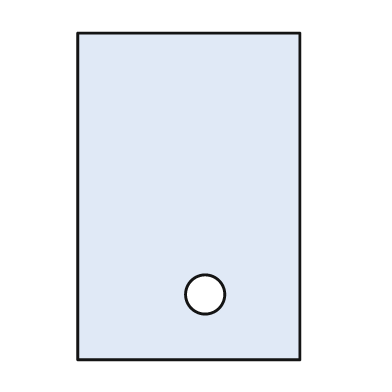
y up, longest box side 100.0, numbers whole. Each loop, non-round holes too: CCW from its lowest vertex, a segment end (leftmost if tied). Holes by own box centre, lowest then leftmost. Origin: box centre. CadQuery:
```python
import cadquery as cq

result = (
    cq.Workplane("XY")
    .moveTo(-34.0, -50.0)
    .lineTo(34.0, -50.0)
    .lineTo(34.0, 50.0)
    .lineTo(-34.0, 50.0)
    .close()
    .moveTo(5.0, -30.0)
    .circle(6.0)
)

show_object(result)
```